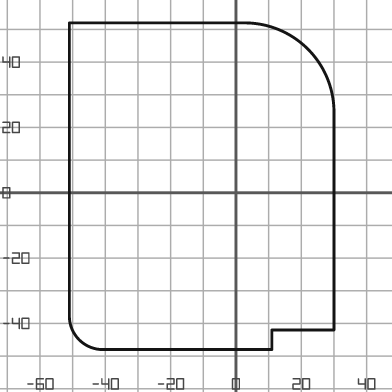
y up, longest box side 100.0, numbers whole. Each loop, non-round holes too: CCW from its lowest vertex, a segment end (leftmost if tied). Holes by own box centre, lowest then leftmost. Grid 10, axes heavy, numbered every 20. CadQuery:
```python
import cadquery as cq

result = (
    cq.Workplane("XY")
    .moveTo(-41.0, -48.0)
    .lineTo(11.0, -48.0)
    .lineTo(11.0, -42.0)
    .lineTo(30.0, -42.0)
    .lineTo(30.0, 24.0)
    .threePointArc((22.0, 44.0), (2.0, 52.0))
    .lineTo(-51.0, 52.0)
    .lineTo(-51.0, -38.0)
    .threePointArc((-48.0, -45.0), (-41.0, -48.0))
    .close()
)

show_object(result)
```